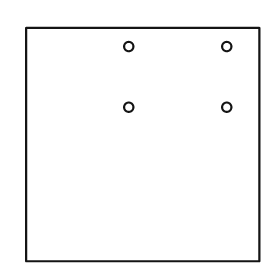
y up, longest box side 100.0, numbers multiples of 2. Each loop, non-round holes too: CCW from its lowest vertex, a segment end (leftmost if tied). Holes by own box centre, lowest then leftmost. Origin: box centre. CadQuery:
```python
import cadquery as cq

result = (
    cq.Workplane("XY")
    .moveTo(-50.0, -50.0)
    .lineTo(50.0, -50.0)
    .lineTo(50.0, 50.0)
    .lineTo(-50.0, 50.0)
    .close()
    .moveTo(-6.0, 16.0)
    .circle(2.0)
    .moveTo(36.0, 16.0)
    .circle(2.0)
    .moveTo(-6.0, 42.0)
    .circle(2.0)
    .moveTo(36.0, 42.0)
    .circle(2.0)
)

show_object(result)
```